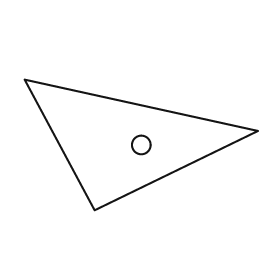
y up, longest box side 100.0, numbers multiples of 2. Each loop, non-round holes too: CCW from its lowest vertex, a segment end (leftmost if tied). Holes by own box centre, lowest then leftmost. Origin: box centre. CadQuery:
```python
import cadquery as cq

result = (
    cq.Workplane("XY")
    .moveTo(-20.0, -28.0)
    .lineTo(50.0, 6.0)
    .lineTo(-50.0, 28.0)
    .close()
    .moveTo(0.0, 0.0)
    .circle(4.0)
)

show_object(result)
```